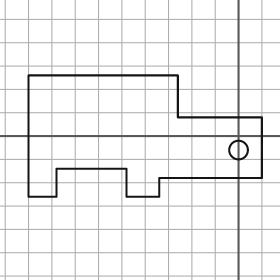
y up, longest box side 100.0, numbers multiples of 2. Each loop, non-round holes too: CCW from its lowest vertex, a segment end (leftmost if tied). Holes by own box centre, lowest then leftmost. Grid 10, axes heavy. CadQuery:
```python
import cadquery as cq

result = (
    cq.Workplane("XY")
    .moveTo(-90.0, -26.0)
    .lineTo(-78.0, -26.0)
    .lineTo(-78.0, -14.0)
    .lineTo(-48.0, -14.0)
    .lineTo(-48.0, -26.0)
    .lineTo(-34.0, -26.0)
    .lineTo(-34.0, -18.0)
    .lineTo(10.0, -18.0)
    .lineTo(10.0, 8.0)
    .lineTo(-26.0, 8.0)
    .lineTo(-26.0, 26.0)
    .lineTo(-90.0, 26.0)
    .close()
    .moveTo(0.0, -6.0)
    .circle(4.0)
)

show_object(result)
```